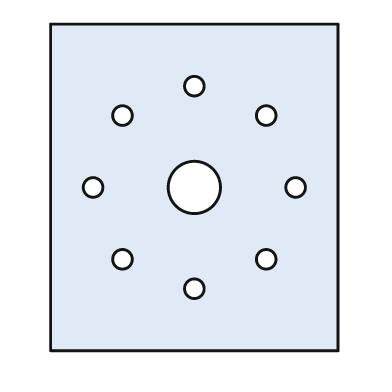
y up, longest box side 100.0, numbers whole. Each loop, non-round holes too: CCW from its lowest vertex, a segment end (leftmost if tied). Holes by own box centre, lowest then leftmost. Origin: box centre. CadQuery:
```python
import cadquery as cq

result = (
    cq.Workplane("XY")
    .moveTo(-44.0, -50.0)
    .lineTo(44.0, -50.0)
    .lineTo(44.0, 50.0)
    .lineTo(-44.0, 50.0)
    .close()
    .moveTo(0.0, -31.0)
    .circle(3.0)
    .moveTo(-22.0, -22.0)
    .circle(3.0)
    .moveTo(22.0, -22.0)
    .circle(3.0)
    .moveTo(-31.0, 0.0)
    .circle(3.0)
    .moveTo(0.0, 0.0)
    .circle(8.0)
    .moveTo(31.0, 0.0)
    .circle(3.0)
    .moveTo(-22.0, 22.0)
    .circle(3.0)
    .moveTo(22.0, 22.0)
    .circle(3.0)
    .moveTo(0.0, 31.0)
    .circle(3.0)
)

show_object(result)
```